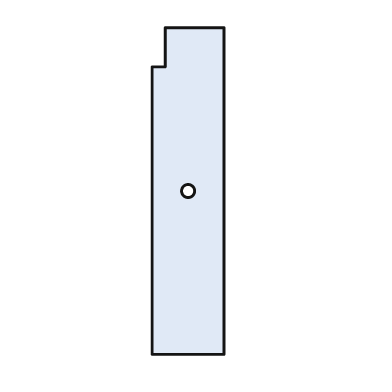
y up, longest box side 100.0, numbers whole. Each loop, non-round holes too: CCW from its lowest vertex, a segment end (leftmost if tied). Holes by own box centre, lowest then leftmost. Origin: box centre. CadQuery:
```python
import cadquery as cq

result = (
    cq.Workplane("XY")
    .moveTo(-11.0, -50.0)
    .lineTo(11.0, -50.0)
    .lineTo(11.0, 50.0)
    .lineTo(-7.0, 50.0)
    .lineTo(-7.0, 38.0)
    .lineTo(-11.0, 38.0)
    .close()
    .moveTo(0.0, 0.0)
    .circle(2.0)
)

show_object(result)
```